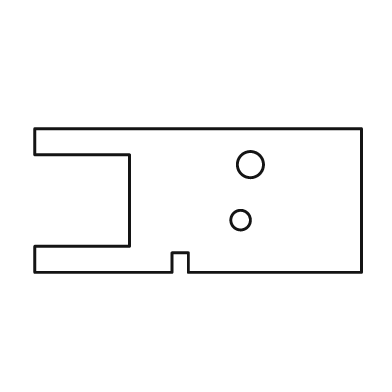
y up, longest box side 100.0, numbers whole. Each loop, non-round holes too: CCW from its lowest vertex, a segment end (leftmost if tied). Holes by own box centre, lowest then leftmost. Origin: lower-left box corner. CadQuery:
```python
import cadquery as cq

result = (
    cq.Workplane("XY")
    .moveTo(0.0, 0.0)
    .lineTo(42.0, 0.0)
    .lineTo(42.0, 6.0)
    .lineTo(47.0, 6.0)
    .lineTo(47.0, 0.0)
    .lineTo(100.0, 0.0)
    .lineTo(100.0, 44.0)
    .lineTo(0.0, 44.0)
    .lineTo(0.0, 36.0)
    .lineTo(29.0, 36.0)
    .lineTo(29.0, 8.0)
    .lineTo(0.0, 8.0)
    .close()
    .moveTo(63.0, 16.0)
    .circle(3.0)
    .moveTo(66.0, 33.0)
    .circle(4.0)
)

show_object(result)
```